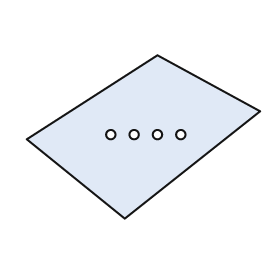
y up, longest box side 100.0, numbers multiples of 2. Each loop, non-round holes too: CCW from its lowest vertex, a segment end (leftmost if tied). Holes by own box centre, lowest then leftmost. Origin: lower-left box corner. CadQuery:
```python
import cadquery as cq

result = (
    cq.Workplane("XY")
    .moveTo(42.0, 0.0)
    .lineTo(100.0, 46.0)
    .lineTo(56.0, 70.0)
    .lineTo(0.0, 34.0)
    .close()
    .moveTo(36.0, 36.0)
    .circle(2.0)
    .moveTo(46.0, 36.0)
    .circle(2.0)
    .moveTo(56.0, 36.0)
    .circle(2.0)
    .moveTo(66.0, 36.0)
    .circle(2.0)
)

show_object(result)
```